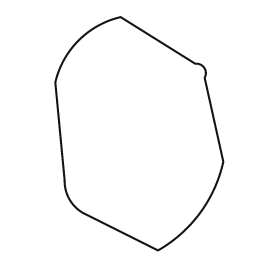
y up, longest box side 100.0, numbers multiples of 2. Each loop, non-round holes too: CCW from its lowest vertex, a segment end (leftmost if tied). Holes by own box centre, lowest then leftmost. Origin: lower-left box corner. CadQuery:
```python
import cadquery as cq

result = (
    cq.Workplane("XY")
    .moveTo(44.0, 0.0)
    .threePointArc((62.0, 16.0), (72.0, 38.0))
    .lineTo(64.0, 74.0)
    .threePointArc((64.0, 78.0), (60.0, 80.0))
    .lineTo(28.0, 100.0)
    .threePointArc((10.0, 90.0), (0.0, 72.0))
    .lineTo(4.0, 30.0)
    .threePointArc((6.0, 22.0), (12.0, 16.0))
    .close()
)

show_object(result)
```